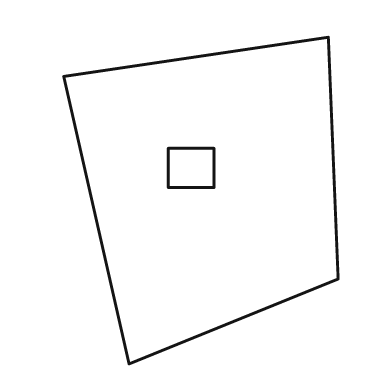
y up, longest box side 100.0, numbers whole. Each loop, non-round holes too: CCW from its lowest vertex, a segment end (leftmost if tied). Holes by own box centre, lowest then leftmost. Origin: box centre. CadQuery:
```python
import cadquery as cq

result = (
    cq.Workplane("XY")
    .moveTo(-22.0, -50.0)
    .lineTo(42.0, -24.0)
    .lineTo(39.0, 50.0)
    .lineTo(-42.0, 38.0)
    .close()
    .moveTo(-10.0, 4.0)
    .lineTo(4.0, 4.0)
    .lineTo(4.0, 16.0)
    .lineTo(-10.0, 16.0)
    .close()
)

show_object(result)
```